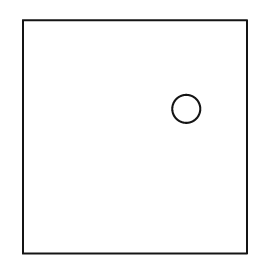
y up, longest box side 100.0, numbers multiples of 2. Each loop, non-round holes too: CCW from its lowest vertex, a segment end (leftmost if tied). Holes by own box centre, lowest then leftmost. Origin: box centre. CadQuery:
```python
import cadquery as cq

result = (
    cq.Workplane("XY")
    .moveTo(-48.0, -50.0)
    .lineTo(48.0, -50.0)
    .lineTo(48.0, 50.0)
    .lineTo(-48.0, 50.0)
    .close()
    .moveTo(22.0, 12.0)
    .circle(6.0)
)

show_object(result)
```